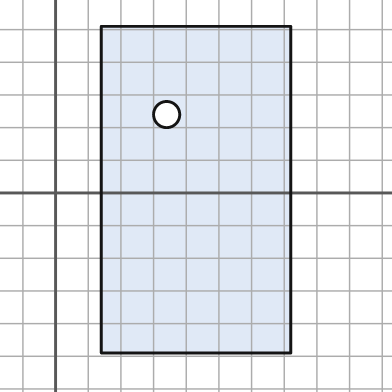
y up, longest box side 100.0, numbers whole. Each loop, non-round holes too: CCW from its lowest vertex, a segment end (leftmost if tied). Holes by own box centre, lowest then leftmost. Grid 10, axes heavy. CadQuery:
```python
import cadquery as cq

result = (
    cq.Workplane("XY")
    .moveTo(14.0, -49.0)
    .lineTo(72.0, -49.0)
    .lineTo(72.0, 51.0)
    .lineTo(14.0, 51.0)
    .close()
    .moveTo(34.0, 24.0)
    .circle(4.0)
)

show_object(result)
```